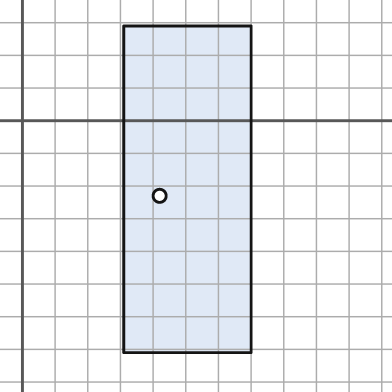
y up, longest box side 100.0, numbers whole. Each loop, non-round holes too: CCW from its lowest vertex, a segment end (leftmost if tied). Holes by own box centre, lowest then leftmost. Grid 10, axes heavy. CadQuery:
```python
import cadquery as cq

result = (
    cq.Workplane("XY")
    .moveTo(31.0, -71.0)
    .lineTo(70.0, -71.0)
    .lineTo(70.0, 29.0)
    .lineTo(31.0, 29.0)
    .close()
    .moveTo(42.0, -23.0)
    .circle(2.0)
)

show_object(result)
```